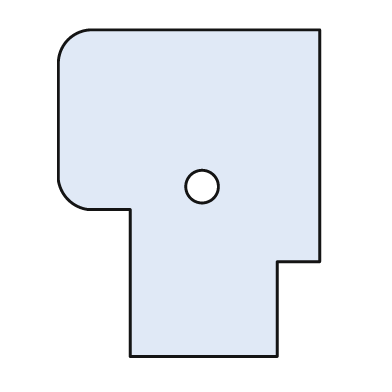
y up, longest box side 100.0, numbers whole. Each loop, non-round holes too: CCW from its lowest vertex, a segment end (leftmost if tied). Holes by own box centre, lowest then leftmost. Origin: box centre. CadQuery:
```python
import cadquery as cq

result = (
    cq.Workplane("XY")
    .moveTo(-18.0, -50.0)
    .lineTo(27.0, -50.0)
    .lineTo(27.0, -21.0)
    .lineTo(40.0, -21.0)
    .lineTo(40.0, 50.0)
    .lineTo(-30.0, 50.0)
    .threePointArc((-37.0, 47.0), (-40.0, 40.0))
    .lineTo(-40.0, 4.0)
    .threePointArc((-37.0, -2.0), (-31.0, -5.0))
    .lineTo(-18.0, -5.0)
    .close()
    .moveTo(4.0, 2.0)
    .circle(5.0)
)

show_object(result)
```